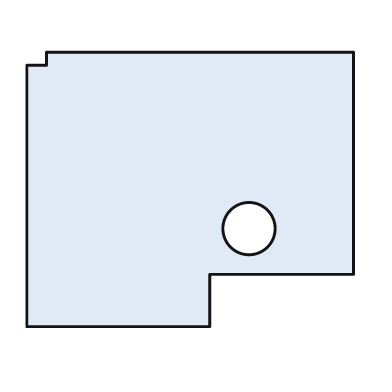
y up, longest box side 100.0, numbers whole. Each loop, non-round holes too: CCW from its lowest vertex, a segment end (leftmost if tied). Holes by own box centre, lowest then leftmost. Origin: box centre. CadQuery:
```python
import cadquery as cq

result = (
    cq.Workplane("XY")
    .moveTo(-50.0, -42.0)
    .lineTo(6.0, -42.0)
    .lineTo(6.0, -26.0)
    .lineTo(50.0, -26.0)
    .lineTo(50.0, 42.0)
    .lineTo(-44.0, 42.0)
    .lineTo(-44.0, 38.0)
    .lineTo(-50.0, 38.0)
    .close()
    .moveTo(18.0, -12.0)
    .circle(8.0)
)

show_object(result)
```